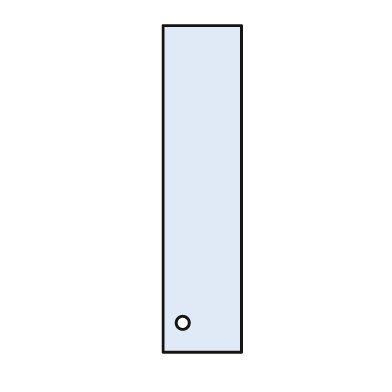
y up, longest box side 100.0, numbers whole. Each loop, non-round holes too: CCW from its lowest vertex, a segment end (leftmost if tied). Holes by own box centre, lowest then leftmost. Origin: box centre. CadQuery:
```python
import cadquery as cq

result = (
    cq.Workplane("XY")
    .moveTo(-12.0, -50.0)
    .lineTo(12.0, -50.0)
    .lineTo(12.0, 50.0)
    .lineTo(-12.0, 50.0)
    .close()
    .moveTo(-6.0, -41.0)
    .circle(2.0)
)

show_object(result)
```